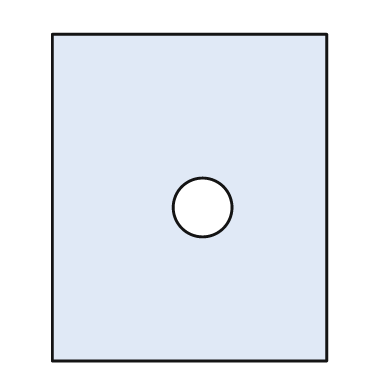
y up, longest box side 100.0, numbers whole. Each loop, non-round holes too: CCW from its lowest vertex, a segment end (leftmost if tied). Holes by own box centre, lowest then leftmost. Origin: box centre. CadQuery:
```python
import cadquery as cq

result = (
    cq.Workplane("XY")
    .moveTo(-42.0, -50.0)
    .lineTo(42.0, -50.0)
    .lineTo(42.0, 50.0)
    .lineTo(-42.0, 50.0)
    .close()
    .moveTo(4.0, -3.0)
    .circle(9.0)
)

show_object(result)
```